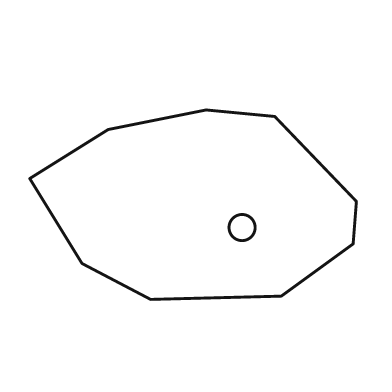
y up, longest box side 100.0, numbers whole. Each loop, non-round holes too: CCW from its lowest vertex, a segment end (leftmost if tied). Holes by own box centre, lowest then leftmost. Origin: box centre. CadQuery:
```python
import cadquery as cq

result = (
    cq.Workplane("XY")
    .moveTo(-13.0, -29.0)
    .lineTo(27.0, -28.0)
    .lineTo(49.0, -12.0)
    .lineTo(50.0, 1.0)
    .lineTo(25.0, 27.0)
    .lineTo(4.0, 29.0)
    .lineTo(-26.0, 23.0)
    .lineTo(-50.0, 8.0)
    .lineTo(-34.0, -18.0)
    .close()
    .moveTo(15.0, -7.0)
    .circle(4.0)
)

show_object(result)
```